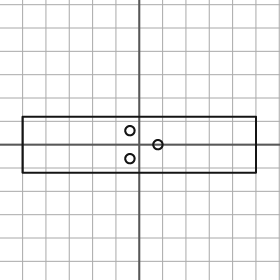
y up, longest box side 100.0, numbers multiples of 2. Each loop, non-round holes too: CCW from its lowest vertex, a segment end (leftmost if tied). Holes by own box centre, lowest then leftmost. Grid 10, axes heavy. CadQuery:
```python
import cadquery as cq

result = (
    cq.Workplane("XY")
    .moveTo(-50.0, -12.0)
    .lineTo(50.0, -12.0)
    .lineTo(50.0, 12.0)
    .lineTo(-50.0, 12.0)
    .close()
    .moveTo(-4.0, -6.0)
    .circle(2.0)
    .moveTo(8.0, 0.0)
    .circle(2.0)
    .moveTo(-4.0, 6.0)
    .circle(2.0)
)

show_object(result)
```